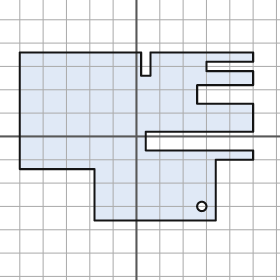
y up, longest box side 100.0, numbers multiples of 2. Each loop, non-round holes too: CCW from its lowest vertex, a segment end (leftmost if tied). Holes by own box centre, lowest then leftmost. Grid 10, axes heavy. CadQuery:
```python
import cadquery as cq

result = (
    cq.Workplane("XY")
    .moveTo(-18.0, -36.0)
    .lineTo(34.0, -36.0)
    .lineTo(34.0, -10.0)
    .lineTo(50.0, -10.0)
    .lineTo(50.0, -6.0)
    .lineTo(4.0, -6.0)
    .lineTo(4.0, 2.0)
    .lineTo(50.0, 2.0)
    .lineTo(50.0, 14.0)
    .lineTo(26.0, 14.0)
    .lineTo(26.0, 22.0)
    .lineTo(50.0, 22.0)
    .lineTo(50.0, 28.0)
    .lineTo(30.0, 28.0)
    .lineTo(30.0, 32.0)
    .lineTo(50.0, 32.0)
    .lineTo(50.0, 36.0)
    .lineTo(6.0, 36.0)
    .lineTo(6.0, 26.0)
    .lineTo(2.0, 26.0)
    .lineTo(2.0, 36.0)
    .lineTo(-50.0, 36.0)
    .lineTo(-50.0, -14.0)
    .lineTo(-18.0, -14.0)
    .close()
    .moveTo(28.0, -30.0)
    .circle(2.0)
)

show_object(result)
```